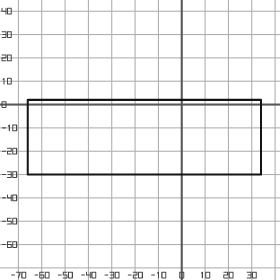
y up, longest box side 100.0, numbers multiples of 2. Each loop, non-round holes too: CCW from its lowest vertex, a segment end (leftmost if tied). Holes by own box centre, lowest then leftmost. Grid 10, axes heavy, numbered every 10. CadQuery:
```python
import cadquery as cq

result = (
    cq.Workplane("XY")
    .moveTo(-66.0, -30.0)
    .lineTo(34.0, -30.0)
    .lineTo(34.0, 2.0)
    .lineTo(-66.0, 2.0)
    .close()
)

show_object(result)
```